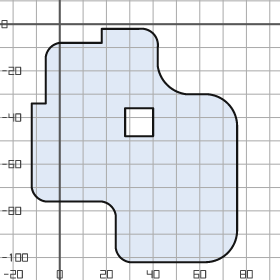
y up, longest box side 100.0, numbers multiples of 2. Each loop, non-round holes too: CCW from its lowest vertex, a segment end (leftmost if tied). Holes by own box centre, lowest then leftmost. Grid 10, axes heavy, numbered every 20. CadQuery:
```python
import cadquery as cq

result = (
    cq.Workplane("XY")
    .moveTo(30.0, -102.0)
    .lineTo(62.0, -102.0)
    .threePointArc((72.0, -98.0), (76.0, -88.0))
    .lineTo(76.0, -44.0)
    .threePointArc((72.0, -34.0), (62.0, -30.0))
    .lineTo(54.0, -30.0)
    .threePointArc((46.0, -26.0), (42.0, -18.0))
    .lineTo(42.0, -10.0)
    .threePointArc((40.0, -4.0), (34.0, -2.0))
    .lineTo(18.0, -2.0)
    .lineTo(18.0, -8.0)
    .lineTo(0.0, -8.0)
    .threePointArc((-4.0, -10.0), (-6.0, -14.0))
    .lineTo(-6.0, -34.0)
    .lineTo(-12.0, -34.0)
    .lineTo(-12.0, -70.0)
    .threePointArc((-10.0, -74.0), (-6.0, -76.0))
    .lineTo(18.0, -76.0)
    .threePointArc((22.0, -78.0), (24.0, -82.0))
    .lineTo(24.0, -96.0)
    .threePointArc((26.0, -100.0), (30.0, -102.0))
    .close()
    .moveTo(28.0, -48.0)
    .lineTo(40.0, -48.0)
    .lineTo(40.0, -36.0)
    .lineTo(28.0, -36.0)
    .close()
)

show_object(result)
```